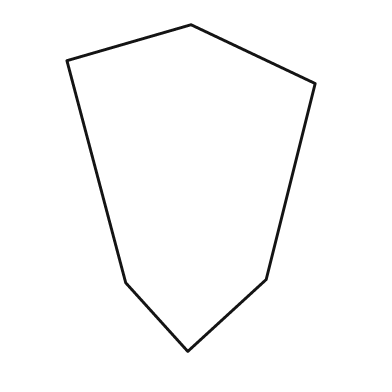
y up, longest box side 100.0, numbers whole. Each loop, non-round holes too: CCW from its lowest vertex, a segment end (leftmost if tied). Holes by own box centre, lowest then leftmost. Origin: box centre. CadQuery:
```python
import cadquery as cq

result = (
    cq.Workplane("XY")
    .moveTo(-1.0, -50.0)
    .lineTo(23.0, -28.0)
    .lineTo(38.0, 32.0)
    .lineTo(0.0, 50.0)
    .lineTo(-38.0, 39.0)
    .lineTo(-20.0, -29.0)
    .close()
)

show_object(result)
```